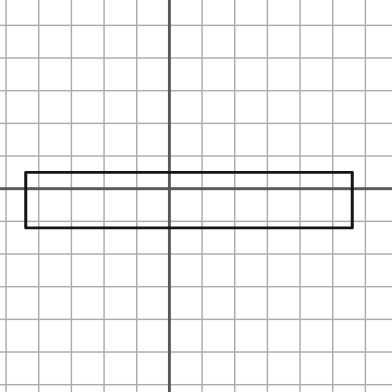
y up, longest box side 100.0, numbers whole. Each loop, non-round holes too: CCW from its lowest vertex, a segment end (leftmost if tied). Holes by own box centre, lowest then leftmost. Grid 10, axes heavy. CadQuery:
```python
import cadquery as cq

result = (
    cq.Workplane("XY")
    .moveTo(-44.0, -12.0)
    .lineTo(56.0, -12.0)
    .lineTo(56.0, 5.0)
    .lineTo(-44.0, 5.0)
    .close()
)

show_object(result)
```